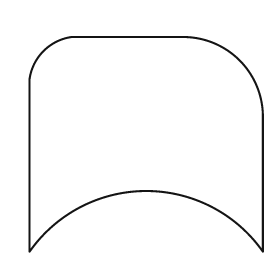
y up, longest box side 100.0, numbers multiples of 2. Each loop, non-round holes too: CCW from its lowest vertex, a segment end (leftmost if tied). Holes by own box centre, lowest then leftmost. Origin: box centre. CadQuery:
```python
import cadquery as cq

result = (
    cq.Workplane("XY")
    .moveTo(-50.0, -46.0)
    .threePointArc((0.0, -20.0), (50.0, -46.0))
    .lineTo(50.0, 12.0)
    .threePointArc((40.0, 36.0), (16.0, 46.0))
    .lineTo(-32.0, 46.0)
    .threePointArc((-44.0, 40.0), (-50.0, 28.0))
    .close()
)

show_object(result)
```